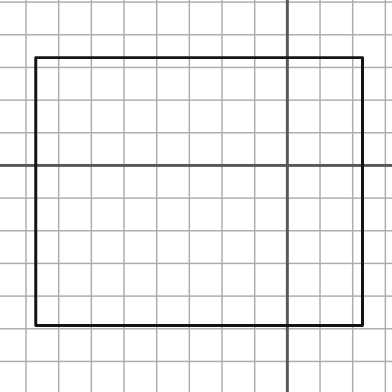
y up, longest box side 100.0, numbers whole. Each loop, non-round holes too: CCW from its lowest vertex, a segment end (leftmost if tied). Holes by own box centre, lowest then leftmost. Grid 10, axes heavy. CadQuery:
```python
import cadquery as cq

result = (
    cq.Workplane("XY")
    .moveTo(-77.0, -49.0)
    .lineTo(23.0, -49.0)
    .lineTo(23.0, 33.0)
    .lineTo(-77.0, 33.0)
    .close()
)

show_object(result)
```